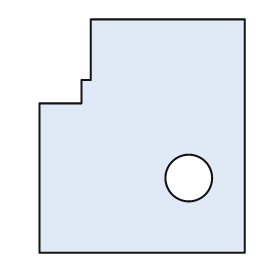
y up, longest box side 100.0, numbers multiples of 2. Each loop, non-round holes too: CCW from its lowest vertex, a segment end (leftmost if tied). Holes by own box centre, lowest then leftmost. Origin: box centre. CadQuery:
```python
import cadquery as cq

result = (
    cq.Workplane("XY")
    .moveTo(-44.0, -50.0)
    .lineTo(44.0, -50.0)
    .lineTo(44.0, 50.0)
    .lineTo(-22.0, 50.0)
    .lineTo(-22.0, 24.0)
    .lineTo(-26.0, 24.0)
    .lineTo(-26.0, 14.0)
    .lineTo(-44.0, 14.0)
    .close()
    .moveTo(20.0, -18.0)
    .circle(10.0)
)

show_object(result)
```